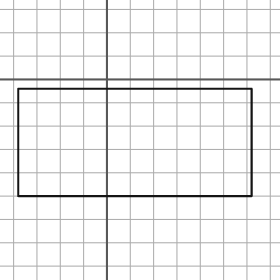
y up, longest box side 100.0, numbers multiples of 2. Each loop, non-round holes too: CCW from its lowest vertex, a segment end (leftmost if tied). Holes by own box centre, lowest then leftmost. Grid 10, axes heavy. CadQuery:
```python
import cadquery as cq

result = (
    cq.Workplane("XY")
    .moveTo(-38.0, -50.0)
    .lineTo(62.0, -50.0)
    .lineTo(62.0, -4.0)
    .lineTo(-38.0, -4.0)
    .close()
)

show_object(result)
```